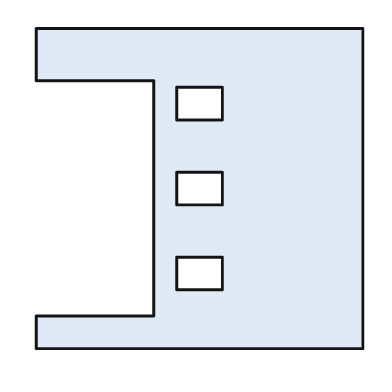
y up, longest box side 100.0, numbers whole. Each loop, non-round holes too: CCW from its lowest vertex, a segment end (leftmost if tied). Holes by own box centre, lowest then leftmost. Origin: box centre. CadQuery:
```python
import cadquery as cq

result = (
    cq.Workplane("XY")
    .moveTo(-50.0, -49.0)
    .lineTo(50.0, -49.0)
    .lineTo(50.0, 49.0)
    .lineTo(-50.0, 49.0)
    .lineTo(-50.0, 33.0)
    .lineTo(-14.0, 33.0)
    .lineTo(-14.0, -39.0)
    .lineTo(-50.0, -39.0)
    .close()
    .moveTo(-7.0, -31.0)
    .lineTo(7.0, -31.0)
    .lineTo(7.0, -21.0)
    .lineTo(-7.0, -21.0)
    .close()
    .moveTo(-7.0, -5.0)
    .lineTo(7.0, -5.0)
    .lineTo(7.0, 5.0)
    .lineTo(-7.0, 5.0)
    .close()
    .moveTo(-7.0, 21.0)
    .lineTo(7.0, 21.0)
    .lineTo(7.0, 31.0)
    .lineTo(-7.0, 31.0)
    .close()
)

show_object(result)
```